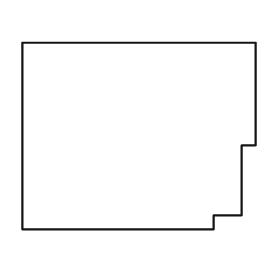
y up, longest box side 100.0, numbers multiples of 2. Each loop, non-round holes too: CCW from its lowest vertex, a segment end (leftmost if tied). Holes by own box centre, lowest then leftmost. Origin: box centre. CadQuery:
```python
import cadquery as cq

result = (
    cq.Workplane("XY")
    .moveTo(-50.0, -40.0)
    .lineTo(32.0, -40.0)
    .lineTo(32.0, -34.0)
    .lineTo(44.0, -34.0)
    .lineTo(44.0, -4.0)
    .lineTo(50.0, -4.0)
    .lineTo(50.0, 40.0)
    .lineTo(-50.0, 40.0)
    .close()
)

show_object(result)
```